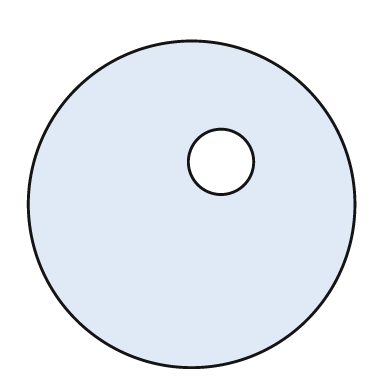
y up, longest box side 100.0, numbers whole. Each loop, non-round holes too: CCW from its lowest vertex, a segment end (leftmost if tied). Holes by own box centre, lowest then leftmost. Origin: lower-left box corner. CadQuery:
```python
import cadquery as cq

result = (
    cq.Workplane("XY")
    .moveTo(50.0, 50.0)
    .circle(50.0)
    .moveTo(59.0, 63.0)
    .circle(10.0)
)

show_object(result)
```